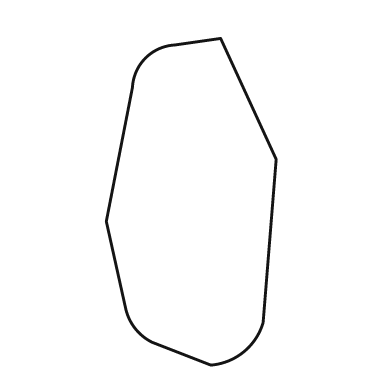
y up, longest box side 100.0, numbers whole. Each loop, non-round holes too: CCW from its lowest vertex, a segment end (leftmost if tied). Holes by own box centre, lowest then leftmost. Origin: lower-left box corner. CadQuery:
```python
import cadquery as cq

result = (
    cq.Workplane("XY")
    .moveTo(32.0, 0.0)
    .threePointArc((42.0, 4.0), (48.0, 13.0))
    .lineTo(52.0, 63.0)
    .lineTo(35.0, 100.0)
    .lineTo(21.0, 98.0)
    .threePointArc((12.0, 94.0), (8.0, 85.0))
    .lineTo(0.0, 44.0)
    .lineTo(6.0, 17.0)
    .threePointArc((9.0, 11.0), (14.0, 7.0))
    .close()
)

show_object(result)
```